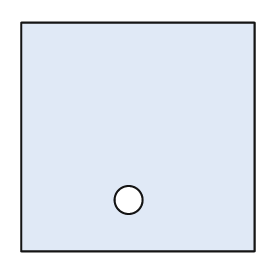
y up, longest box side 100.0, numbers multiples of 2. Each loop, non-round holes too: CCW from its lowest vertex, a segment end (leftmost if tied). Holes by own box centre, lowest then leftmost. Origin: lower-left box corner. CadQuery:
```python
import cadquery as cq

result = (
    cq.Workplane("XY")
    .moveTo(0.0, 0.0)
    .lineTo(100.0, 0.0)
    .lineTo(100.0, 98.0)
    .lineTo(0.0, 98.0)
    .close()
    .moveTo(46.0, 22.0)
    .circle(6.0)
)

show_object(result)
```